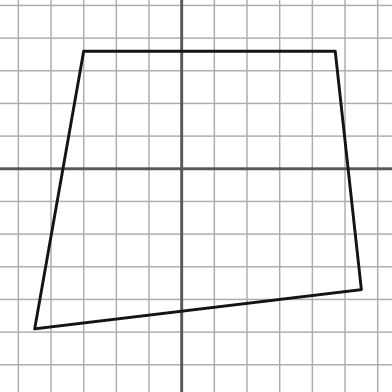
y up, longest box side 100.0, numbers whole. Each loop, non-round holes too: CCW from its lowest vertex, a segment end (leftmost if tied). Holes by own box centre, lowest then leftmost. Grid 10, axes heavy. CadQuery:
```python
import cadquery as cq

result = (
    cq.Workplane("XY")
    .moveTo(-45.0, -49.0)
    .lineTo(55.0, -37.0)
    .lineTo(47.0, 36.0)
    .lineTo(-30.0, 36.0)
    .close()
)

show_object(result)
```